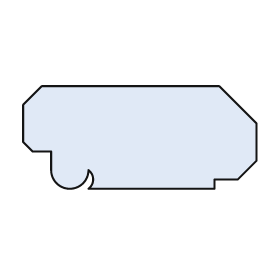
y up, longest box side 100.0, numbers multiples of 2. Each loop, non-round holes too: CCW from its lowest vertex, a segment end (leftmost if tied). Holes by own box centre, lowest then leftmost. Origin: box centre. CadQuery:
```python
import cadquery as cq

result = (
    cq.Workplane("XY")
    .moveTo(-22.0, -22.0)
    .lineTo(32.0, -22.0)
    .lineTo(32.0, -18.0)
    .lineTo(42.0, -18.0)
    .lineTo(50.0, -10.0)
    .lineTo(50.0, 6.0)
    .lineTo(34.0, 22.0)
    .lineTo(-42.0, 22.0)
    .lineTo(-50.0, 14.0)
    .lineTo(-50.0, -2.0)
    .lineTo(-46.0, -6.0)
    .lineTo(-38.0, -6.0)
    .lineTo(-38.0, -14.0)
    .threePointArc((-30.0, -22.0), (-22.0, -14.0))
    .threePointArc((-20.0, -18.0), (-22.0, -22.0))
    .close()
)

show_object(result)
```